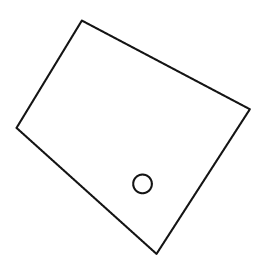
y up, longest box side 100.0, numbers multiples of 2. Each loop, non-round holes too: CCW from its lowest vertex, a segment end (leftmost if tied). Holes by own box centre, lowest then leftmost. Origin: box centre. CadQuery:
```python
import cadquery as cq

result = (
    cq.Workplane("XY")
    .moveTo(10.0, -50.0)
    .lineTo(50.0, 12.0)
    .lineTo(-22.0, 50.0)
    .lineTo(-50.0, 4.0)
    .close()
    .moveTo(4.0, -20.0)
    .circle(4.0)
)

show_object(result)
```